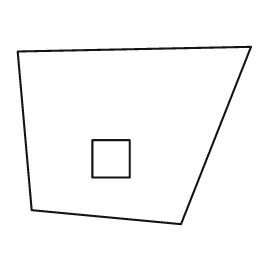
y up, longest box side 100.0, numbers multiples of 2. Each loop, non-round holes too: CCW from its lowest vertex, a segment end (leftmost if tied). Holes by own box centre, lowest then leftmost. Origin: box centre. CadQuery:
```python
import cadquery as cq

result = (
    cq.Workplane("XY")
    .moveTo(20.0, -38.0)
    .lineTo(50.0, 38.0)
    .lineTo(-50.0, 36.0)
    .lineTo(-44.0, -32.0)
    .close()
    .moveTo(-18.0, -18.0)
    .lineTo(-2.0, -18.0)
    .lineTo(-2.0, -2.0)
    .lineTo(-18.0, -2.0)
    .close()
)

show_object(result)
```